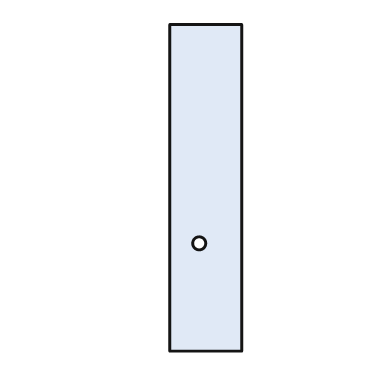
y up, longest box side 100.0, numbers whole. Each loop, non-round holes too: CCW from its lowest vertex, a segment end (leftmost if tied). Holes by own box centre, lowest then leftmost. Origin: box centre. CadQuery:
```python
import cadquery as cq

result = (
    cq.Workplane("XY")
    .moveTo(-11.0, -50.0)
    .lineTo(11.0, -50.0)
    .lineTo(11.0, 50.0)
    .lineTo(-11.0, 50.0)
    .close()
    .moveTo(-2.0, -17.0)
    .circle(2.0)
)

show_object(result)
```